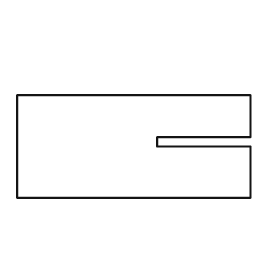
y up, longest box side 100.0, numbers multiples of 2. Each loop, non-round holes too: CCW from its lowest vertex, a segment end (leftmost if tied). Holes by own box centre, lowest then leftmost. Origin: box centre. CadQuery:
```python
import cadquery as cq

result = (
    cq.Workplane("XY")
    .moveTo(-50.0, -22.0)
    .lineTo(50.0, -22.0)
    .lineTo(50.0, 0.0)
    .lineTo(10.0, 0.0)
    .lineTo(10.0, 4.0)
    .lineTo(50.0, 4.0)
    .lineTo(50.0, 22.0)
    .lineTo(-50.0, 22.0)
    .close()
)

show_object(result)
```